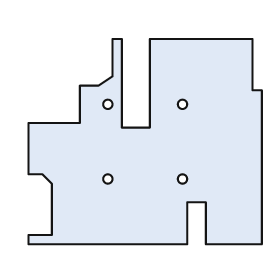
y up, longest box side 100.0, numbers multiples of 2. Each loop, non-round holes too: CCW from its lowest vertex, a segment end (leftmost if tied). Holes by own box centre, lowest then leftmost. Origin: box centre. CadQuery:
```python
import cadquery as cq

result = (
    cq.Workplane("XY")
    .moveTo(-50.0, -44.0)
    .lineTo(18.0, -44.0)
    .lineTo(18.0, -26.0)
    .lineTo(26.0, -26.0)
    .lineTo(26.0, -44.0)
    .lineTo(50.0, -44.0)
    .lineTo(50.0, 22.0)
    .lineTo(46.0, 22.0)
    .lineTo(46.0, 44.0)
    .lineTo(2.0, 44.0)
    .lineTo(2.0, 6.0)
    .lineTo(-10.0, 6.0)
    .lineTo(-10.0, 44.0)
    .lineTo(-14.0, 44.0)
    .lineTo(-14.0, 28.0)
    .lineTo(-20.0, 24.0)
    .lineTo(-28.0, 24.0)
    .lineTo(-28.0, 8.0)
    .lineTo(-50.0, 8.0)
    .lineTo(-50.0, -14.0)
    .lineTo(-44.0, -14.0)
    .lineTo(-40.0, -18.0)
    .lineTo(-40.0, -40.0)
    .lineTo(-50.0, -40.0)
    .close()
    .moveTo(-16.0, -16.0)
    .circle(2.0)
    .moveTo(16.0, -16.0)
    .circle(2.0)
    .moveTo(-16.0, 16.0)
    .circle(2.0)
    .moveTo(16.0, 16.0)
    .circle(2.0)
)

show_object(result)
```